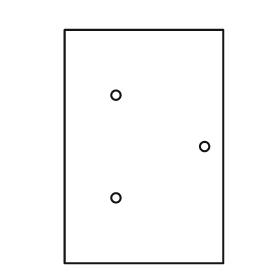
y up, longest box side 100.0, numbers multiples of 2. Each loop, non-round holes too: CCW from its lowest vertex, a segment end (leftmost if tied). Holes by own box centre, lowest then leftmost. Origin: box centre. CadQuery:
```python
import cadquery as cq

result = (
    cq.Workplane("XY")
    .moveTo(-34.0, -50.0)
    .lineTo(34.0, -50.0)
    .lineTo(34.0, 50.0)
    .lineTo(-34.0, 50.0)
    .close()
    .moveTo(-12.0, -22.0)
    .circle(2.0)
    .moveTo(26.0, 0.0)
    .circle(2.0)
    .moveTo(-12.0, 22.0)
    .circle(2.0)
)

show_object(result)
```